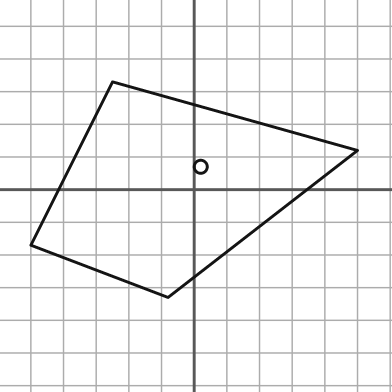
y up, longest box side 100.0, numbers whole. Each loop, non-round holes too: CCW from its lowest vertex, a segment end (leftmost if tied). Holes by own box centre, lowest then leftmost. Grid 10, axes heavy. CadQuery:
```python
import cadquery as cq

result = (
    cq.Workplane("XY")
    .moveTo(-8.0, -33.0)
    .lineTo(50.0, 12.0)
    .lineTo(-25.0, 33.0)
    .lineTo(-50.0, -17.0)
    .close()
    .moveTo(2.0, 7.0)
    .circle(2.0)
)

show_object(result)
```